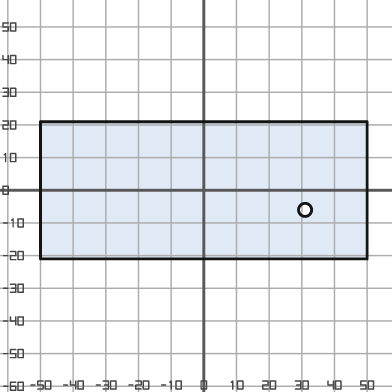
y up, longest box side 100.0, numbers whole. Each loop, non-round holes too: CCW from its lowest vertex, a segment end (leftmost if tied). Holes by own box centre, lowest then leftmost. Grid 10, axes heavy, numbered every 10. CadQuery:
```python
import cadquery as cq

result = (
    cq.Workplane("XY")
    .moveTo(-50.0, -21.0)
    .lineTo(50.0, -21.0)
    .lineTo(50.0, 21.0)
    .lineTo(-50.0, 21.0)
    .close()
    .moveTo(31.0, -6.0)
    .circle(2.0)
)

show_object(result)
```